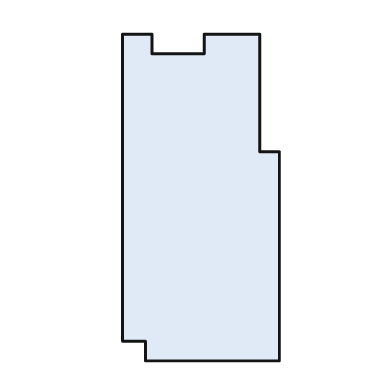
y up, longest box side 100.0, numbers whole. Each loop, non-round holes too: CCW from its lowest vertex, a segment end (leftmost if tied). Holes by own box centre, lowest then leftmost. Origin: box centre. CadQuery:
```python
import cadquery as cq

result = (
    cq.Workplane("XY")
    .moveTo(-17.0, -50.0)
    .lineTo(24.0, -50.0)
    .lineTo(24.0, 14.0)
    .lineTo(18.0, 14.0)
    .lineTo(18.0, 50.0)
    .lineTo(1.0, 50.0)
    .lineTo(1.0, 44.0)
    .lineTo(-15.0, 44.0)
    .lineTo(-15.0, 50.0)
    .lineTo(-24.0, 50.0)
    .lineTo(-24.0, -44.0)
    .lineTo(-17.0, -44.0)
    .close()
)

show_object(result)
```